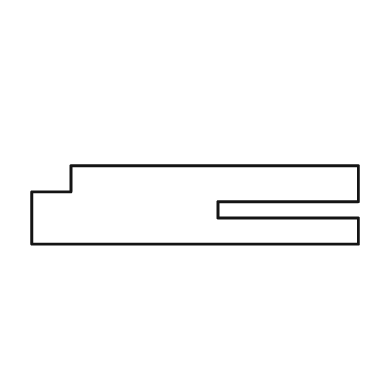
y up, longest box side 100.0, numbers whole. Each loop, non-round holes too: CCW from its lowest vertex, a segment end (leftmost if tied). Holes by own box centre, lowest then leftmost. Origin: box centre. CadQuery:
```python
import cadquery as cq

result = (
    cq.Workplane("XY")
    .moveTo(-50.0, -12.0)
    .lineTo(50.0, -12.0)
    .lineTo(50.0, -4.0)
    .lineTo(7.0, -4.0)
    .lineTo(7.0, 1.0)
    .lineTo(50.0, 1.0)
    .lineTo(50.0, 12.0)
    .lineTo(-38.0, 12.0)
    .lineTo(-38.0, 4.0)
    .lineTo(-50.0, 4.0)
    .close()
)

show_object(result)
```